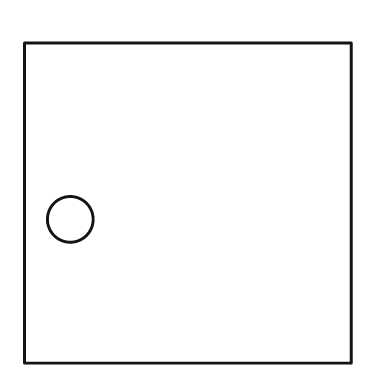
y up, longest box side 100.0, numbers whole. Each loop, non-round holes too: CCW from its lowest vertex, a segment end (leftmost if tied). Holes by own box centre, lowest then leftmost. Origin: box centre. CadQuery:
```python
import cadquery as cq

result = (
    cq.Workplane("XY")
    .moveTo(-50.0, -49.0)
    .lineTo(50.0, -49.0)
    .lineTo(50.0, 49.0)
    .lineTo(-50.0, 49.0)
    .close()
    .moveTo(-36.0, -5.0)
    .circle(7.0)
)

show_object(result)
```